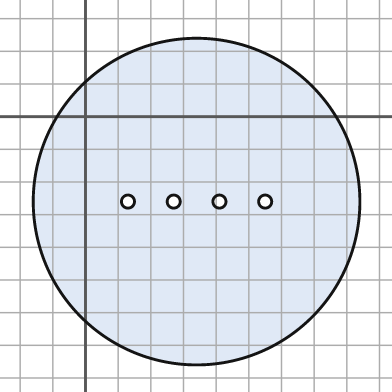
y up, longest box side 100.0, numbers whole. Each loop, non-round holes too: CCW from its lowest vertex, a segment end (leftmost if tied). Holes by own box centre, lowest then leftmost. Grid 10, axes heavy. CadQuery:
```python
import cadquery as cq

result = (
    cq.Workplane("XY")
    .moveTo(34.0, -26.0)
    .circle(50.0)
    .moveTo(13.0, -26.0)
    .circle(2.0)
    .moveTo(27.0, -26.0)
    .circle(2.0)
    .moveTo(41.0, -26.0)
    .circle(2.0)
    .moveTo(55.0, -26.0)
    .circle(2.0)
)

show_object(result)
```